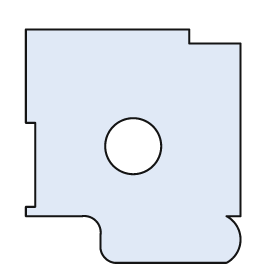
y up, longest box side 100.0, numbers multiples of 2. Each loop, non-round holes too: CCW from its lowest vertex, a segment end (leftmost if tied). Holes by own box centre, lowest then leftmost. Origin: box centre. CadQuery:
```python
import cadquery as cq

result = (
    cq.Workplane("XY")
    .moveTo(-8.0, -50.0)
    .lineTo(40.0, -50.0)
    .threePointArc((46.0, -40.0), (40.0, -30.0))
    .lineTo(46.0, -30.0)
    .lineTo(46.0, 44.0)
    .lineTo(24.0, 44.0)
    .lineTo(24.0, 50.0)
    .lineTo(-46.0, 50.0)
    .lineTo(-46.0, 10.0)
    .lineTo(-42.0, 10.0)
    .lineTo(-42.0, -26.0)
    .lineTo(-46.0, -26.0)
    .lineTo(-46.0, -30.0)
    .lineTo(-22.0, -30.0)
    .threePointArc((-16.0, -32.0), (-14.0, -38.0))
    .lineTo(-14.0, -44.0)
    .threePointArc((-12.0, -48.0), (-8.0, -50.0))
    .close()
    .moveTo(0.0, 0.0)
    .circle(12.0)
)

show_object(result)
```